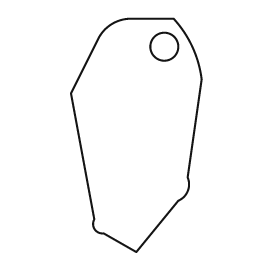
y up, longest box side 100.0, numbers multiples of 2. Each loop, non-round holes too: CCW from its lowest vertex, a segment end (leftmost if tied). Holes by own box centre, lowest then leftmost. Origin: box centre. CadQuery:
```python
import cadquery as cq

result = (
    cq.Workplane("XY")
    .moveTo(0.0, -50.0)
    .lineTo(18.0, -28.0)
    .threePointArc((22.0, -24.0), (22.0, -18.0))
    .lineTo(28.0, 24.0)
    .threePointArc((24.0, 38.0), (16.0, 50.0))
    .lineTo(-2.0, 50.0)
    .threePointArc((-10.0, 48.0), (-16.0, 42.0))
    .lineTo(-28.0, 18.0)
    .lineTo(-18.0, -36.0)
    .threePointArc((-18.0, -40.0), (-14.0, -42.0))
    .close()
    .moveTo(12.0, 38.0)
    .circle(6.0)
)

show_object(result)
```